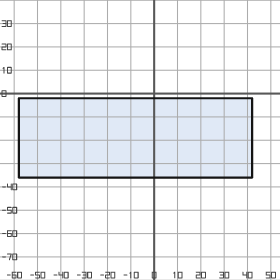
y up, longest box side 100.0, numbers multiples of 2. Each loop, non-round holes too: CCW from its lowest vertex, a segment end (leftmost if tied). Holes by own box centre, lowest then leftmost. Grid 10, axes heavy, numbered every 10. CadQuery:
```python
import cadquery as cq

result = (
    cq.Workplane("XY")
    .moveTo(-58.0, -36.0)
    .lineTo(42.0, -36.0)
    .lineTo(42.0, -2.0)
    .lineTo(-58.0, -2.0)
    .close()
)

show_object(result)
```